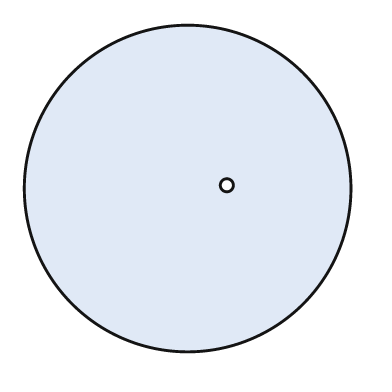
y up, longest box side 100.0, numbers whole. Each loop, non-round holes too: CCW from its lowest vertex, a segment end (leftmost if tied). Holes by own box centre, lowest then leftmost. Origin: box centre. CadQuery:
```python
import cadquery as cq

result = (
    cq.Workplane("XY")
    .moveTo(0.0, 0.0)
    .circle(50.0)
    .moveTo(12.0, 1.0)
    .circle(2.0)
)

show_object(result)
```